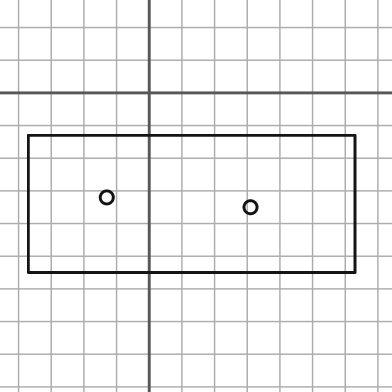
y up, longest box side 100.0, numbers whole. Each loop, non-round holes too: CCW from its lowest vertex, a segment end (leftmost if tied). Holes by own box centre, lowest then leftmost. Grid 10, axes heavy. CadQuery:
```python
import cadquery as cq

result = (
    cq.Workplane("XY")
    .moveTo(-37.0, -55.0)
    .lineTo(63.0, -55.0)
    .lineTo(63.0, -13.0)
    .lineTo(-37.0, -13.0)
    .close()
    .moveTo(31.0, -35.0)
    .circle(2.0)
    .moveTo(-13.0, -32.0)
    .circle(2.0)
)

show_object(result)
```